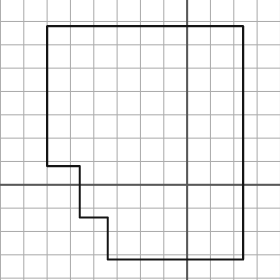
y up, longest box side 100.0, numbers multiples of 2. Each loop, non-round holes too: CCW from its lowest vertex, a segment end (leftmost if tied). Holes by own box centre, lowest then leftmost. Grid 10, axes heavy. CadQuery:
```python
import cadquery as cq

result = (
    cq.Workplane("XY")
    .moveTo(-34.0, -32.0)
    .lineTo(24.0, -32.0)
    .lineTo(24.0, 68.0)
    .lineTo(-60.0, 68.0)
    .lineTo(-60.0, 8.0)
    .lineTo(-46.0, 8.0)
    .lineTo(-46.0, -14.0)
    .lineTo(-34.0, -14.0)
    .close()
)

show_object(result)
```